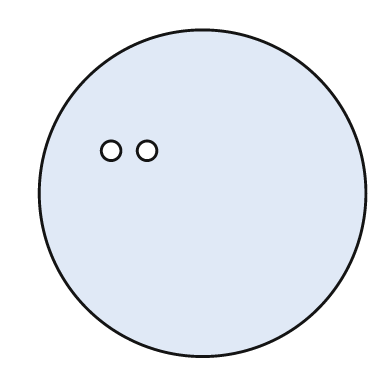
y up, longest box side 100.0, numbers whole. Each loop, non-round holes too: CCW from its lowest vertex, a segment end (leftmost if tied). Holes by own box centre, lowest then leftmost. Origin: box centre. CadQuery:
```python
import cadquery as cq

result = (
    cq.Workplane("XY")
    .moveTo(0.0, 0.0)
    .circle(50.0)
    .moveTo(-28.0, 13.0)
    .circle(3.0)
    .moveTo(-17.0, 13.0)
    .circle(3.0)
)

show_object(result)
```